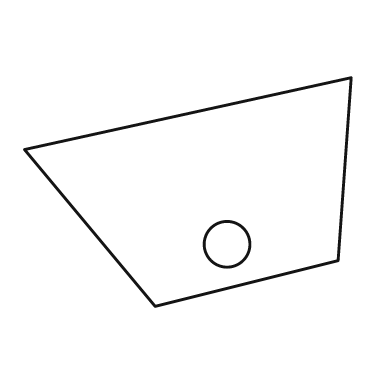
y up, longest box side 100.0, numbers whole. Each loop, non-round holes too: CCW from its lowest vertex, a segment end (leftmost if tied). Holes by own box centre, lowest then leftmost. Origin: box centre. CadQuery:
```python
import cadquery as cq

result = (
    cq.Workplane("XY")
    .moveTo(-10.0, -35.0)
    .lineTo(46.0, -21.0)
    .lineTo(50.0, 35.0)
    .lineTo(-50.0, 13.0)
    .close()
    .moveTo(12.0, -16.0)
    .circle(7.0)
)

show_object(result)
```